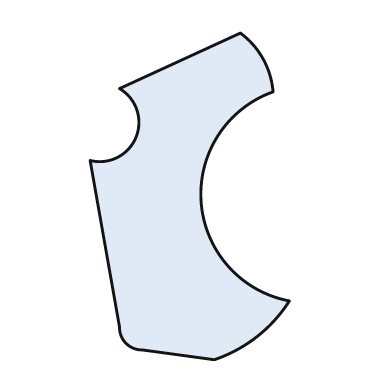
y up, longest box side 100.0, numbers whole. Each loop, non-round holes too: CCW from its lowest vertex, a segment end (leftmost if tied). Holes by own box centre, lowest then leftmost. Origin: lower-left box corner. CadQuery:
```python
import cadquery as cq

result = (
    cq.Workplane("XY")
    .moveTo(38.0, 0.0)
    .threePointArc((51.0, 7.0), (61.0, 18.0))
    .threePointArc((34.0, 48.0), (56.0, 82.0))
    .threePointArc((53.0, 92.0), (46.0, 100.0))
    .lineTo(9.0, 83.0)
    .threePointArc((14.0, 68.0), (0.0, 61.0))
    .lineTo(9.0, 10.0)
    .threePointArc((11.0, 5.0), (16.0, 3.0))
    .close()
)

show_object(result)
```